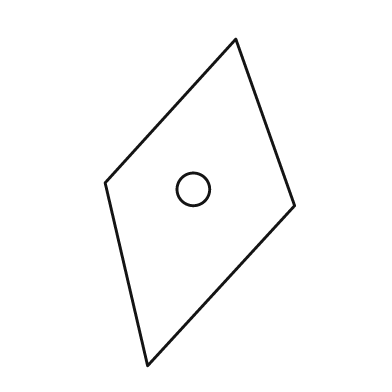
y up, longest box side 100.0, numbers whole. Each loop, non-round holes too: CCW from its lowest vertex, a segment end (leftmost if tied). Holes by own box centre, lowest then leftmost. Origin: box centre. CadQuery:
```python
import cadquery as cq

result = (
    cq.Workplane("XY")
    .moveTo(-16.0, -50.0)
    .lineTo(29.0, -1.0)
    .lineTo(11.0, 50.0)
    .lineTo(-29.0, 6.0)
    .close()
    .moveTo(-2.0, 4.0)
    .circle(5.0)
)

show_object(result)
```